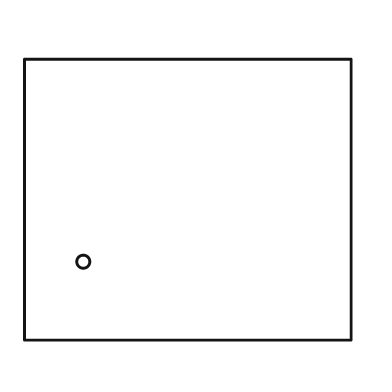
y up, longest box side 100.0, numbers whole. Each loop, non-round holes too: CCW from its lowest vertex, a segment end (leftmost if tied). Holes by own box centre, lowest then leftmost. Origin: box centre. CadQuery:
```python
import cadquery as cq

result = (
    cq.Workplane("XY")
    .moveTo(-50.0, -43.0)
    .lineTo(50.0, -43.0)
    .lineTo(50.0, 43.0)
    .lineTo(-50.0, 43.0)
    .close()
    .moveTo(-32.0, -19.0)
    .circle(2.0)
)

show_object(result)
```